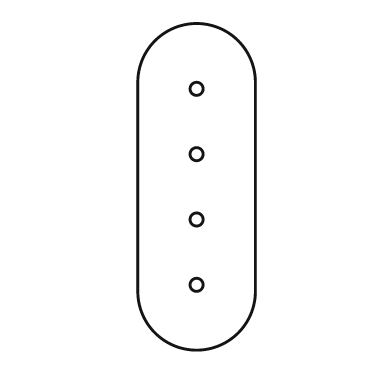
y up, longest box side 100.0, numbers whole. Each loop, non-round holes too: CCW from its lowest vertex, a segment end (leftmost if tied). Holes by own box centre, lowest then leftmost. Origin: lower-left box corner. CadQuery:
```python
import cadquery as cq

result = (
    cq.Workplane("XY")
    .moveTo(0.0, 18.0)
    .threePointArc((18.0, 0.0), (36.0, 18.0))
    .lineTo(36.0, 82.0)
    .threePointArc((18.0, 100.0), (0.0, 82.0))
    .close()
    .moveTo(18.0, 20.0)
    .circle(2.0)
    .moveTo(18.0, 40.0)
    .circle(2.0)
    .moveTo(18.0, 60.0)
    .circle(2.0)
    .moveTo(18.0, 80.0)
    .circle(2.0)
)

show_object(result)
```